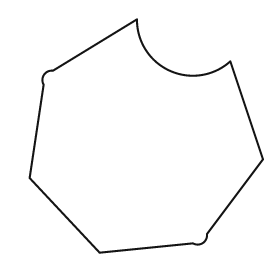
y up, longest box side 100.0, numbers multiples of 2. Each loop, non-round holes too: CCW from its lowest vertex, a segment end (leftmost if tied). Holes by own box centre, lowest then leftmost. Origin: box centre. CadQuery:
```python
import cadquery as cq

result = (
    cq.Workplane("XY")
    .moveTo(-20.0, -50.0)
    .lineTo(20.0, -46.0)
    .threePointArc((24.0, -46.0), (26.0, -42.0))
    .lineTo(50.0, -10.0)
    .lineTo(36.0, 32.0)
    .threePointArc((10.0, 28.0), (-4.0, 50.0))
    .lineTo(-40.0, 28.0)
    .threePointArc((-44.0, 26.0), (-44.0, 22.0))
    .lineTo(-50.0, -18.0)
    .close()
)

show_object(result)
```